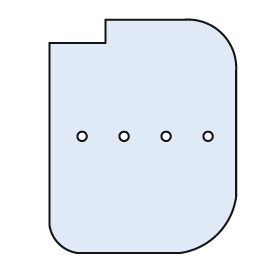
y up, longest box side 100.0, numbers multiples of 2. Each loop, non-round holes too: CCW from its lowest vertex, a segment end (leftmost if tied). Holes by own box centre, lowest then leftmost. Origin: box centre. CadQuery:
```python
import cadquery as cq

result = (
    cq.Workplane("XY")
    .moveTo(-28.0, -50.0)
    .lineTo(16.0, -50.0)
    .threePointArc((32.0, -42.0), (40.0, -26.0))
    .lineTo(40.0, 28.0)
    .threePointArc((34.0, 44.0), (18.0, 50.0))
    .lineTo(-16.0, 50.0)
    .lineTo(-16.0, 40.0)
    .lineTo(-40.0, 40.0)
    .lineTo(-40.0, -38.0)
    .threePointArc((-36.0, -46.0), (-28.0, -50.0))
    .close()
    .moveTo(-26.0, 0.0)
    .circle(2.0)
    .moveTo(-8.0, 0.0)
    .circle(2.0)
    .moveTo(10.0, 0.0)
    .circle(2.0)
    .moveTo(28.0, 0.0)
    .circle(2.0)
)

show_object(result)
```